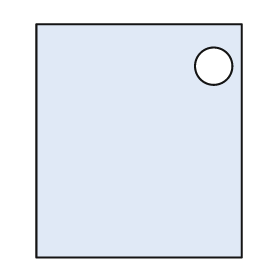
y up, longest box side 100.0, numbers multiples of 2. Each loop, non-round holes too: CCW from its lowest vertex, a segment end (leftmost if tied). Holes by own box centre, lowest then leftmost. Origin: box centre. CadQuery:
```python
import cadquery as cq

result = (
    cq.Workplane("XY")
    .moveTo(-44.0, -50.0)
    .lineTo(44.0, -50.0)
    .lineTo(44.0, 50.0)
    .lineTo(-44.0, 50.0)
    .close()
    .moveTo(32.0, 32.0)
    .circle(8.0)
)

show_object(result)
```